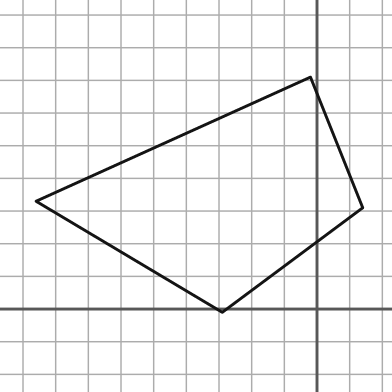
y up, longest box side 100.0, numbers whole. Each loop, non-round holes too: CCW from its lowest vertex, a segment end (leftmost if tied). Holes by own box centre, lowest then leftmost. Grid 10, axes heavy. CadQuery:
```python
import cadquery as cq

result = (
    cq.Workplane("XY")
    .moveTo(-29.0, -1.0)
    .lineTo(14.0, 31.0)
    .lineTo(-2.0, 71.0)
    .lineTo(-86.0, 33.0)
    .close()
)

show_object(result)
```